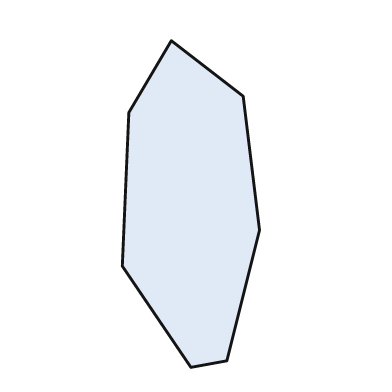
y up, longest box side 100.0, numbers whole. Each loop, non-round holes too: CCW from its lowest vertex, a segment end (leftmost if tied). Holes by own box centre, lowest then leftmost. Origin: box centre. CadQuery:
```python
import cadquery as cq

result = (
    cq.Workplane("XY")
    .moveTo(0.0, -50.0)
    .lineTo(11.0, -48.0)
    .lineTo(21.0, -8.0)
    .lineTo(16.0, 33.0)
    .lineTo(-6.0, 50.0)
    .lineTo(-19.0, 28.0)
    .lineTo(-21.0, -19.0)
    .close()
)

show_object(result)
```